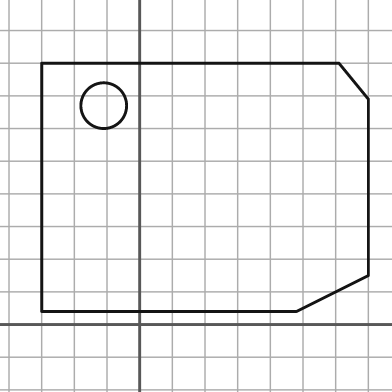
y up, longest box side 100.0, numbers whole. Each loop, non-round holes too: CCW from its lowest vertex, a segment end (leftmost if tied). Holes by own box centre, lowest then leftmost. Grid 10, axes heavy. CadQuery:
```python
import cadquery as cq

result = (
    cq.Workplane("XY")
    .moveTo(-30.0, 4.0)
    .lineTo(48.0, 4.0)
    .lineTo(70.0, 15.0)
    .lineTo(70.0, 69.0)
    .lineTo(61.0, 80.0)
    .lineTo(-30.0, 80.0)
    .close()
    .moveTo(-11.0, 67.0)
    .circle(7.0)
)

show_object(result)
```